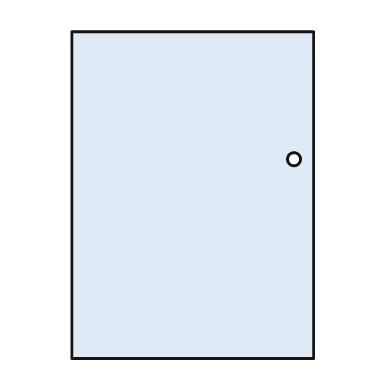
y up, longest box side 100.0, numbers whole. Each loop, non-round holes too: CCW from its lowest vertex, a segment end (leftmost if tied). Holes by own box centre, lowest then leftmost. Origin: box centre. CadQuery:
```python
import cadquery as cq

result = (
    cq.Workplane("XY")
    .moveTo(-37.0, -50.0)
    .lineTo(37.0, -50.0)
    .lineTo(37.0, 50.0)
    .lineTo(-37.0, 50.0)
    .close()
    .moveTo(31.0, 11.0)
    .circle(2.0)
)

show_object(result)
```